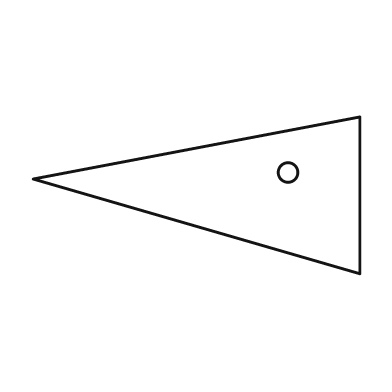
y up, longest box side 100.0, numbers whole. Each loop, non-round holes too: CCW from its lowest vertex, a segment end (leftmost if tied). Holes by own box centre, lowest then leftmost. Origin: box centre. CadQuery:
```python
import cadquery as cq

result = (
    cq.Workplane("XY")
    .moveTo(50.0, -24.0)
    .lineTo(50.0, 24.0)
    .lineTo(-50.0, 5.0)
    .close()
    .moveTo(28.0, 7.0)
    .circle(3.0)
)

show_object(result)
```